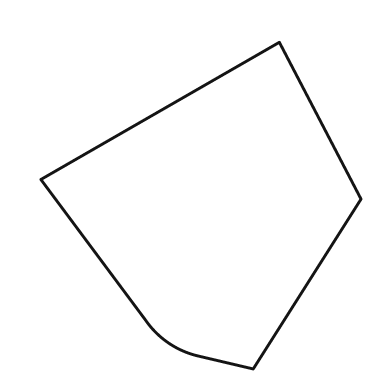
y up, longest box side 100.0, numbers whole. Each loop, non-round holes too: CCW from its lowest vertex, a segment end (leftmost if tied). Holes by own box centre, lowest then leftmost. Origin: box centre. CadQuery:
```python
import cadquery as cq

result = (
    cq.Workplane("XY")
    .moveTo(16.0, -50.0)
    .lineTo(49.0, 2.0)
    .lineTo(24.0, 50.0)
    .lineTo(-49.0, 8.0)
    .lineTo(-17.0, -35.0)
    .threePointArc((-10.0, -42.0), (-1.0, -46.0))
    .close()
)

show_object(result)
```